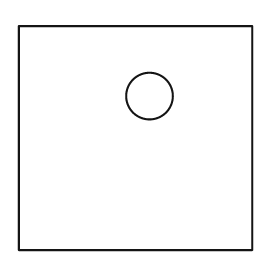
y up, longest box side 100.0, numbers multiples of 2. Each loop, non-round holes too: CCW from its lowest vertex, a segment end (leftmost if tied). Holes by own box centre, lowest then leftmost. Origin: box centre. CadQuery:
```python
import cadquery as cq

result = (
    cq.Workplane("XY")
    .moveTo(-50.0, -48.0)
    .lineTo(50.0, -48.0)
    .lineTo(50.0, 48.0)
    .lineTo(-50.0, 48.0)
    .close()
    .moveTo(6.0, 18.0)
    .circle(10.0)
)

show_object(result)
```